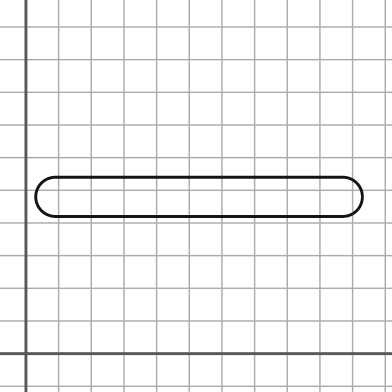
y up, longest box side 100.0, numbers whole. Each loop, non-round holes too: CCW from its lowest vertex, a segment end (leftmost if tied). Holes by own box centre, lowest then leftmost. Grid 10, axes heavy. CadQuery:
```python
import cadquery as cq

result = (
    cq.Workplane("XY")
    .moveTo(9.0, 42.0)
    .lineTo(97.0, 42.0)
    .threePointArc((103.0, 48.0), (97.0, 54.0))
    .lineTo(9.0, 54.0)
    .threePointArc((3.0, 48.0), (9.0, 42.0))
    .close()
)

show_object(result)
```